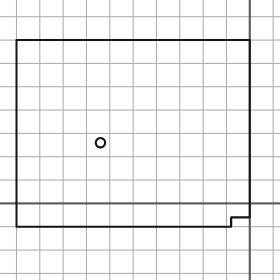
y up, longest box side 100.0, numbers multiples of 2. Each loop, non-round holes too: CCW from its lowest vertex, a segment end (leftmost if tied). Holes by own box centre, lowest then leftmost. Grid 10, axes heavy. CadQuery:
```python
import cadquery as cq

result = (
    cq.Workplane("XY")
    .moveTo(-100.0, -10.0)
    .lineTo(-8.0, -10.0)
    .lineTo(-8.0, -6.0)
    .lineTo(0.0, -6.0)
    .lineTo(0.0, 70.0)
    .lineTo(-100.0, 70.0)
    .close()
    .moveTo(-64.0, 26.0)
    .circle(2.0)
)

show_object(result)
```